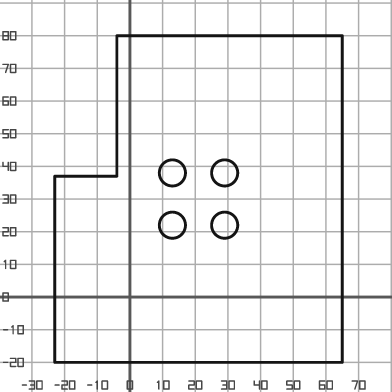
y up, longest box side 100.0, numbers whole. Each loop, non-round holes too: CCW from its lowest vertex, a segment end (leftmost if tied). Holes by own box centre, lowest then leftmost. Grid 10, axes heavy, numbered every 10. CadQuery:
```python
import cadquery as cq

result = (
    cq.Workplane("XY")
    .moveTo(-23.0, -20.0)
    .lineTo(65.0, -20.0)
    .lineTo(65.0, 80.0)
    .lineTo(-4.0, 80.0)
    .lineTo(-4.0, 37.0)
    .lineTo(-23.0, 37.0)
    .close()
    .moveTo(13.0, 22.0)
    .circle(4.0)
    .moveTo(29.0, 22.0)
    .circle(4.0)
    .moveTo(13.0, 38.0)
    .circle(4.0)
    .moveTo(29.0, 38.0)
    .circle(4.0)
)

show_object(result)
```